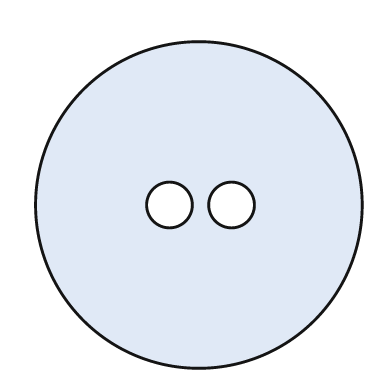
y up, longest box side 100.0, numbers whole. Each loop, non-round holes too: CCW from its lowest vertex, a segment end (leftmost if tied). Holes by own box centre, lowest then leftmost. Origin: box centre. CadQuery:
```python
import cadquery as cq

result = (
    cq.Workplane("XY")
    .moveTo(0.0, 0.0)
    .circle(50.0)
    .moveTo(-9.0, 0.0)
    .circle(7.0)
    .moveTo(10.0, 0.0)
    .circle(7.0)
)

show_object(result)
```